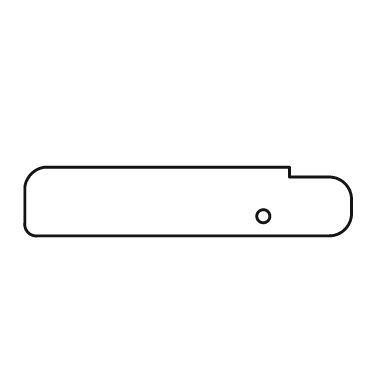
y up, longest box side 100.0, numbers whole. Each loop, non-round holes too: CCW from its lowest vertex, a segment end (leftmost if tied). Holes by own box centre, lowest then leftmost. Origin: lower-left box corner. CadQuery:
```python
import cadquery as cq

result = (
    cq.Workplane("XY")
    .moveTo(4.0, 0.0)
    .lineTo(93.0, 0.0)
    .threePointArc((98.0, 2.0), (100.0, 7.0))
    .lineTo(100.0, 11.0)
    .threePointArc((98.0, 16.0), (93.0, 18.0))
    .lineTo(81.0, 18.0)
    .lineTo(81.0, 21.0)
    .lineTo(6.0, 21.0)
    .threePointArc((2.0, 19.0), (0.0, 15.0))
    .lineTo(0.0, 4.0)
    .threePointArc((1.0, 1.0), (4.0, 0.0))
    .close()
    .moveTo(73.0, 6.0)
    .circle(2.0)
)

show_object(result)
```